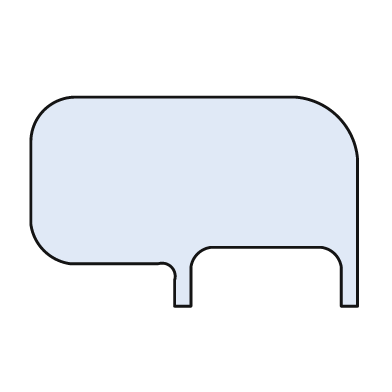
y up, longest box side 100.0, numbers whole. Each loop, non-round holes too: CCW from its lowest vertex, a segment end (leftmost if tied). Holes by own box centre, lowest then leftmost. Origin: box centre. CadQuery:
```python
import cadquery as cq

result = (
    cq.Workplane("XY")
    .moveTo(-6.0, -32.0)
    .lineTo(-1.0, -32.0)
    .lineTo(-1.0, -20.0)
    .threePointArc((1.0, -16.0), (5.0, -14.0))
    .lineTo(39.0, -14.0)
    .threePointArc((43.0, -16.0), (45.0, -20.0))
    .lineTo(45.0, -32.0)
    .lineTo(50.0, -32.0)
    .lineTo(50.0, 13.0)
    .threePointArc((44.0, 26.0), (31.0, 32.0))
    .lineTo(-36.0, 32.0)
    .threePointArc((-46.0, 28.0), (-50.0, 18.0))
    .lineTo(-50.0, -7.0)
    .threePointArc((-46.0, -15.0), (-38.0, -19.0))
    .lineTo(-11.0, -19.0)
    .threePointArc((-7.0, -20.0), (-6.0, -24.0))
    .close()
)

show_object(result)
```